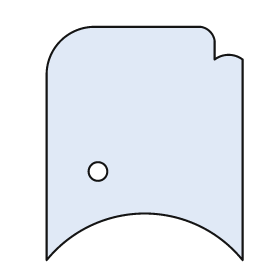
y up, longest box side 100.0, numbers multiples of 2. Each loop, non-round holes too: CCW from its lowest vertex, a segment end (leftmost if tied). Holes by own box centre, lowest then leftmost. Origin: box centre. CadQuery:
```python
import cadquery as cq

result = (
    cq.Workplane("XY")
    .moveTo(-42.0, -50.0)
    .threePointArc((0.0, -30.0), (42.0, -50.0))
    .lineTo(42.0, 36.0)
    .threePointArc((36.0, 38.0), (30.0, 36.0))
    .lineTo(30.0, 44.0)
    .threePointArc((28.0, 48.0), (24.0, 50.0))
    .lineTo(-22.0, 50.0)
    .threePointArc((-36.0, 44.0), (-42.0, 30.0))
    .close()
    .moveTo(-20.0, -12.0)
    .circle(4.0)
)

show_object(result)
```